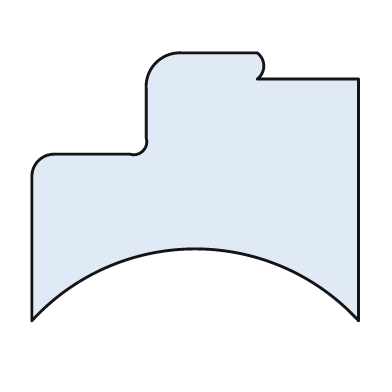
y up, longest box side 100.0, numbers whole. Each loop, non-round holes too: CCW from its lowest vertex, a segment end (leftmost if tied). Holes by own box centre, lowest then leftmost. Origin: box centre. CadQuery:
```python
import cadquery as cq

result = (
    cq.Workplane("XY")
    .moveTo(-50.0, -41.0)
    .threePointArc((0.0, -19.0), (50.0, -41.0))
    .lineTo(50.0, 33.0)
    .lineTo(19.0, 33.0)
    .threePointArc((21.0, 37.0), (19.0, 41.0))
    .lineTo(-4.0, 41.0)
    .threePointArc((-12.0, 38.0), (-15.0, 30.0))
    .lineTo(-15.0, 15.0)
    .threePointArc((-16.0, 11.0), (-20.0, 10.0))
    .lineTo(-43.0, 10.0)
    .threePointArc((-48.0, 8.0), (-50.0, 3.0))
    .close()
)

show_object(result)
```